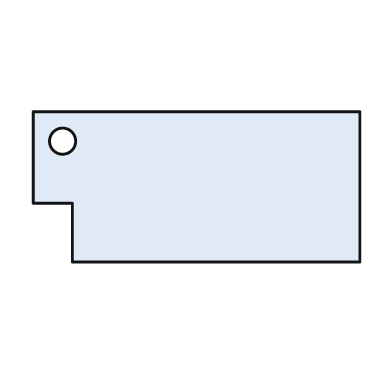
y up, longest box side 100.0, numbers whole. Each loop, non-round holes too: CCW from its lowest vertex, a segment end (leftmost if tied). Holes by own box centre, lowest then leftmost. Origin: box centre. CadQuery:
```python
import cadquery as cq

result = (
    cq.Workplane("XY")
    .moveTo(-38.0, -23.0)
    .lineTo(50.0, -23.0)
    .lineTo(50.0, 23.0)
    .lineTo(-50.0, 23.0)
    .lineTo(-50.0, -5.0)
    .lineTo(-38.0, -5.0)
    .close()
    .moveTo(-41.0, 14.0)
    .circle(4.0)
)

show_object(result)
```